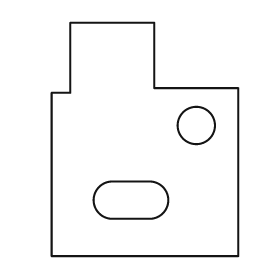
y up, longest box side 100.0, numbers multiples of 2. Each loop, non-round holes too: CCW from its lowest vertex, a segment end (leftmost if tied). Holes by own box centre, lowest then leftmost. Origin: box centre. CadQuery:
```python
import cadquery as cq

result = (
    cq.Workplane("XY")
    .moveTo(-40.0, -50.0)
    .lineTo(40.0, -50.0)
    .lineTo(40.0, 22.0)
    .lineTo(4.0, 22.0)
    .lineTo(4.0, 50.0)
    .lineTo(-32.0, 50.0)
    .lineTo(-32.0, 20.0)
    .lineTo(-40.0, 20.0)
    .close()
    .moveTo(-14.0, -34.0)
    .lineTo(2.0, -34.0)
    .threePointArc((10.0, -26.0), (2.0, -18.0))
    .lineTo(-14.0, -18.0)
    .threePointArc((-22.0, -26.0), (-14.0, -34.0))
    .close()
    .moveTo(22.0, 6.0)
    .circle(8.0)
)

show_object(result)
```